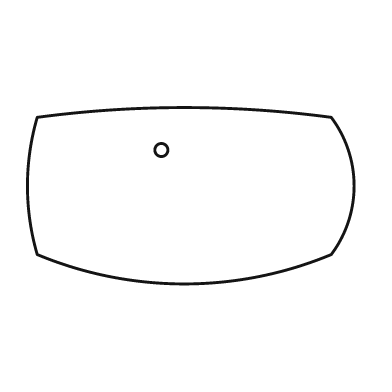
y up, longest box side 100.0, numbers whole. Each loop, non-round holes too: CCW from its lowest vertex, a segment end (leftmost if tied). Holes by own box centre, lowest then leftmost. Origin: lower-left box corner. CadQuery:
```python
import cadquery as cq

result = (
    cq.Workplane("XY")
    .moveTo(3.0, 9.0)
    .threePointArc((48.0, 0.0), (93.0, 9.0))
    .threePointArc((100.0, 30.0), (93.0, 51.0))
    .threePointArc((48.0, 54.0), (3.0, 51.0))
    .threePointArc((0.0, 30.0), (3.0, 9.0))
    .close()
    .moveTo(41.0, 41.0)
    .circle(2.0)
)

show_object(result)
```